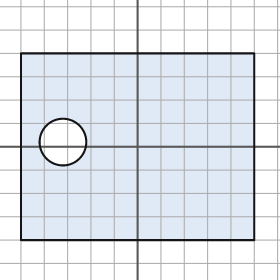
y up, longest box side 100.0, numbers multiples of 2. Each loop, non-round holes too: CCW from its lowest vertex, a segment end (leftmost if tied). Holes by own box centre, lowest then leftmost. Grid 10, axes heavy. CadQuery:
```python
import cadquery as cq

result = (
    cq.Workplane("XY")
    .moveTo(-50.0, -40.0)
    .lineTo(50.0, -40.0)
    .lineTo(50.0, 40.0)
    .lineTo(-50.0, 40.0)
    .close()
    .moveTo(-32.0, 2.0)
    .circle(10.0)
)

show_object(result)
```